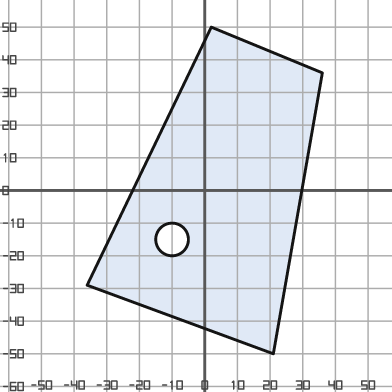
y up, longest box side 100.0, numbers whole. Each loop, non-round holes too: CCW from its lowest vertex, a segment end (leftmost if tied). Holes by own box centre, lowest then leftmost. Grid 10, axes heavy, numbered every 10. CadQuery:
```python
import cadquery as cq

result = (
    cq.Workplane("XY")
    .moveTo(21.0, -50.0)
    .lineTo(36.0, 36.0)
    .lineTo(2.0, 50.0)
    .lineTo(-36.0, -29.0)
    .close()
    .moveTo(-10.0, -15.0)
    .circle(5.0)
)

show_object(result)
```